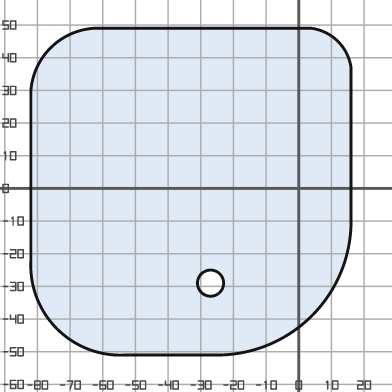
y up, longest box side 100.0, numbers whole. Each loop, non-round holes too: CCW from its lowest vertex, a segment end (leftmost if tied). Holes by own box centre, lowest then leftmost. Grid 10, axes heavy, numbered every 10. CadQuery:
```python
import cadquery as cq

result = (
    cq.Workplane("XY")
    .moveTo(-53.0, -51.0)
    .lineTo(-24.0, -51.0)
    .threePointArc((4.0, -39.0), (16.0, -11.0))
    .lineTo(16.0, 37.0)
    .threePointArc((12.0, 45.0), (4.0, 49.0))
    .lineTo(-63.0, 49.0)
    .threePointArc((-76.0, 43.0), (-82.0, 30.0))
    .lineTo(-82.0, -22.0)
    .threePointArc((-74.0, -43.0), (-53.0, -51.0))
    .close()
    .moveTo(-27.0, -29.0)
    .circle(4.0)
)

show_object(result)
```